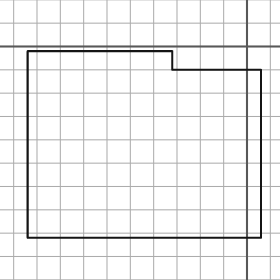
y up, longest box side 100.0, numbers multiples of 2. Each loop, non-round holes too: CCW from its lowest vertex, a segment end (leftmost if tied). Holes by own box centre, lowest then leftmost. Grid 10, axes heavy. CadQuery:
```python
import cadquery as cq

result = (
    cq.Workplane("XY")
    .moveTo(-94.0, -82.0)
    .lineTo(6.0, -82.0)
    .lineTo(6.0, -10.0)
    .lineTo(-32.0, -10.0)
    .lineTo(-32.0, -2.0)
    .lineTo(-94.0, -2.0)
    .close()
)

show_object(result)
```